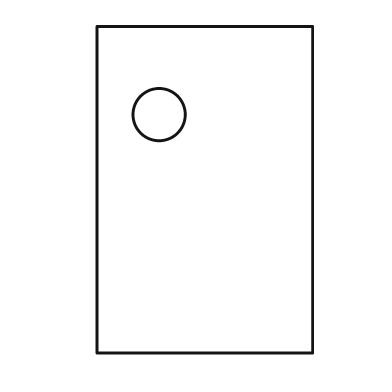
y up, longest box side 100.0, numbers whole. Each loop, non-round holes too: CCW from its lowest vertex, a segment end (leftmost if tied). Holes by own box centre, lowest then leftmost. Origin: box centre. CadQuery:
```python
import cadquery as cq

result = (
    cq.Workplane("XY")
    .moveTo(-33.0, -50.0)
    .lineTo(33.0, -50.0)
    .lineTo(33.0, 50.0)
    .lineTo(-33.0, 50.0)
    .close()
    .moveTo(-14.0, 23.0)
    .circle(8.0)
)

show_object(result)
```